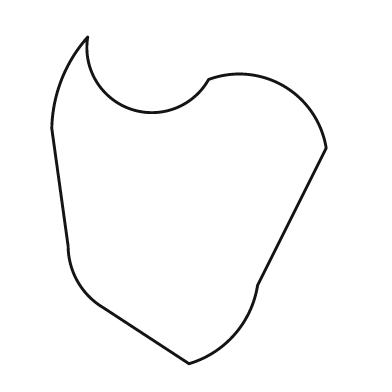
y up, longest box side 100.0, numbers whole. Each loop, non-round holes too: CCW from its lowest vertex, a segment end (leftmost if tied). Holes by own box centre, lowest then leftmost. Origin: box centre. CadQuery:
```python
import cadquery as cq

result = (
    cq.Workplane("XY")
    .moveTo(0.0, -50.0)
    .threePointArc((14.0, -41.0), (21.0, -26.0))
    .lineTo(42.0, 16.0)
    .threePointArc((29.0, 35.0), (6.0, 37.0))
    .threePointArc((-18.0, 28.0), (-31.0, 50.0))
    .threePointArc((-39.0, 37.0), (-42.0, 22.0))
    .lineTo(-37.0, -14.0)
    .threePointArc((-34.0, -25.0), (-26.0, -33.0))
    .close()
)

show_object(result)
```